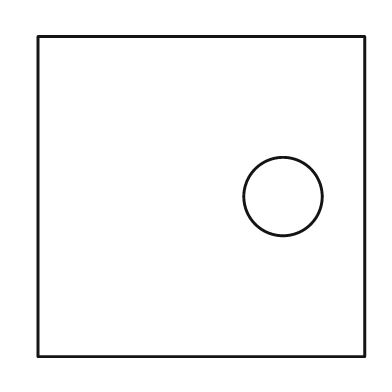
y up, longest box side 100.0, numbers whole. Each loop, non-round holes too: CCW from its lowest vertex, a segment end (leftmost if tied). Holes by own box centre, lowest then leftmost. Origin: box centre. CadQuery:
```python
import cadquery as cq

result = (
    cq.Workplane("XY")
    .moveTo(-50.0, -49.0)
    .lineTo(50.0, -49.0)
    .lineTo(50.0, 49.0)
    .lineTo(-50.0, 49.0)
    .close()
    .moveTo(25.0, 0.0)
    .circle(12.0)
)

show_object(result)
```